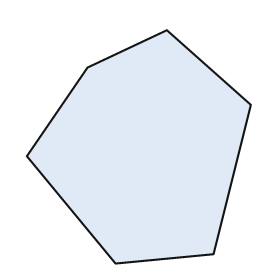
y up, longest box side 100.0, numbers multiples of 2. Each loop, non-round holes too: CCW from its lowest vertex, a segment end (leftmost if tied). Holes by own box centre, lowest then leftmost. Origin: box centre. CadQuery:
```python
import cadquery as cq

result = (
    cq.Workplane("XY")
    .moveTo(-10.0, -50.0)
    .lineTo(32.0, -46.0)
    .lineTo(48.0, 18.0)
    .lineTo(12.0, 50.0)
    .lineTo(-22.0, 34.0)
    .lineTo(-48.0, -4.0)
    .close()
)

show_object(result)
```